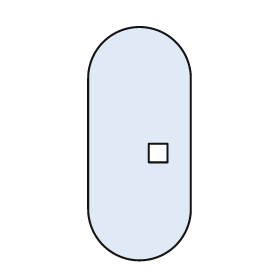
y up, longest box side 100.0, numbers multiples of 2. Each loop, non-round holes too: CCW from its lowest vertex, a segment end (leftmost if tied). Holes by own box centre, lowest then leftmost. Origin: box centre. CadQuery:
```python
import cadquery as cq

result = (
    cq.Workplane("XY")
    .moveTo(-22.0, -28.0)
    .threePointArc((0.0, -50.0), (22.0, -28.0))
    .lineTo(22.0, 28.0)
    .threePointArc((0.0, 50.0), (-22.0, 28.0))
    .close()
    .moveTo(4.0, -8.0)
    .lineTo(12.0, -8.0)
    .lineTo(12.0, 0.0)
    .lineTo(4.0, 0.0)
    .close()
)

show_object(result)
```